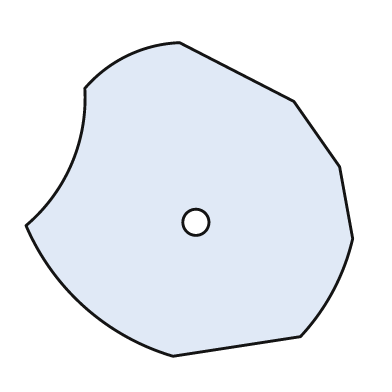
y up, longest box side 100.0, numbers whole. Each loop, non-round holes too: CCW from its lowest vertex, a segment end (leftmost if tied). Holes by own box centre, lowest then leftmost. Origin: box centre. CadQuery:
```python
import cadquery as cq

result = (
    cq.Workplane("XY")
    .moveTo(-5.0, -48.0)
    .lineTo(34.0, -42.0)
    .threePointArc((44.0, -28.0), (50.0, -12.0))
    .lineTo(46.0, 10.0)
    .lineTo(32.0, 30.0)
    .lineTo(-3.0, 48.0)
    .threePointArc((-19.0, 44.0), (-32.0, 34.0))
    .threePointArc((-36.0, 11.0), (-50.0, -8.0))
    .threePointArc((-32.0, -33.0), (-5.0, -48.0))
    .close()
    .moveTo(2.0, -7.0)
    .circle(4.0)
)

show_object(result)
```